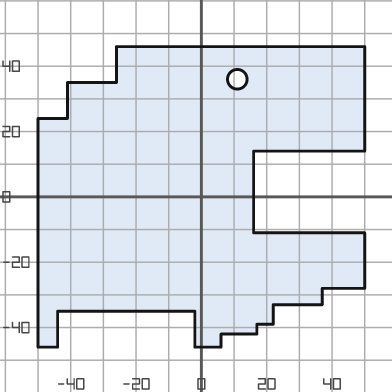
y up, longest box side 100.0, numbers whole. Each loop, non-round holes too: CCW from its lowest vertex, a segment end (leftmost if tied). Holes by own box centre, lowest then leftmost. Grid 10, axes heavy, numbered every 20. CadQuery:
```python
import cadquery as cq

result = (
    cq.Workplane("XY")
    .moveTo(-50.0, -46.0)
    .lineTo(-44.0, -46.0)
    .lineTo(-44.0, -35.0)
    .lineTo(-2.0, -35.0)
    .lineTo(-2.0, -46.0)
    .lineTo(6.0, -46.0)
    .lineTo(6.0, -42.0)
    .lineTo(17.0, -42.0)
    .lineTo(17.0, -39.0)
    .lineTo(22.0, -39.0)
    .lineTo(22.0, -33.0)
    .lineTo(37.0, -33.0)
    .lineTo(37.0, -28.0)
    .lineTo(50.0, -28.0)
    .lineTo(50.0, -11.0)
    .lineTo(16.0, -11.0)
    .lineTo(16.0, 14.0)
    .lineTo(50.0, 14.0)
    .lineTo(50.0, 46.0)
    .lineTo(-26.0, 46.0)
    .lineTo(-26.0, 35.0)
    .lineTo(-41.0, 35.0)
    .lineTo(-41.0, 24.0)
    .lineTo(-50.0, 24.0)
    .close()
    .moveTo(11.0, 36.0)
    .circle(3.0)
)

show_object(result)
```